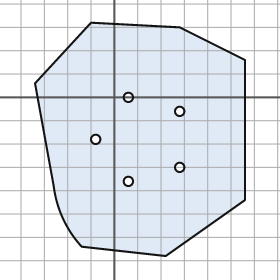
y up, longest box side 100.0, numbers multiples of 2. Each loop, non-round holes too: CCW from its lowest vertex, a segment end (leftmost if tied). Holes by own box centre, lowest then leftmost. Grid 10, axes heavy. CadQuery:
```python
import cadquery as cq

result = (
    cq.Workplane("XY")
    .moveTo(22.0, -68.0)
    .lineTo(56.0, -44.0)
    .lineTo(56.0, 16.0)
    .lineTo(28.0, 30.0)
    .lineTo(-10.0, 32.0)
    .lineTo(-34.0, 6.0)
    .lineTo(-26.0, -38.0)
    .threePointArc((-22.0, -52.0), (-14.0, -64.0))
    .close()
    .moveTo(6.0, -36.0)
    .circle(2.0)
    .moveTo(28.0, -30.0)
    .circle(2.0)
    .moveTo(-8.0, -18.0)
    .circle(2.0)
    .moveTo(28.0, -6.0)
    .circle(2.0)
    .moveTo(6.0, 0.0)
    .circle(2.0)
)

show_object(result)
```